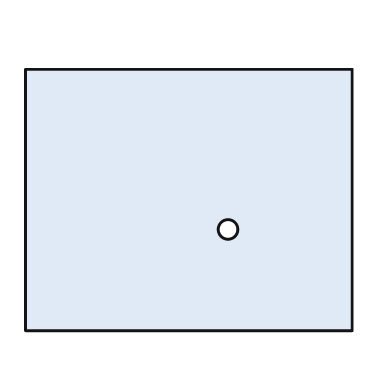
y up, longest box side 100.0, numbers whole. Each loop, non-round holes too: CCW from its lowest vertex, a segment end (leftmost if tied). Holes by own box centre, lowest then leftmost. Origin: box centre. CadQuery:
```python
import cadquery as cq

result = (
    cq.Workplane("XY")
    .moveTo(-50.0, -40.0)
    .lineTo(50.0, -40.0)
    .lineTo(50.0, 40.0)
    .lineTo(-50.0, 40.0)
    .close()
    .moveTo(12.0, -9.0)
    .circle(3.0)
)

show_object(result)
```